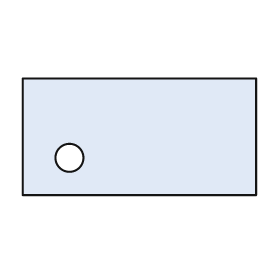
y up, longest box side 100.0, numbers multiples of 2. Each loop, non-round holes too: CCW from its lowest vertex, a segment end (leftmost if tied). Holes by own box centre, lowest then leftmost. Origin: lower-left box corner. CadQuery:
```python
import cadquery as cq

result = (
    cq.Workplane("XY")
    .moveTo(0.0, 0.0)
    .lineTo(100.0, 0.0)
    .lineTo(100.0, 50.0)
    .lineTo(0.0, 50.0)
    .close()
    .moveTo(20.0, 16.0)
    .circle(6.0)
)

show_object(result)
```